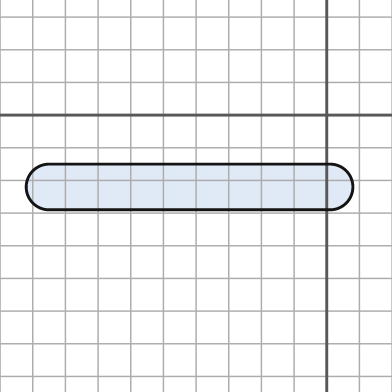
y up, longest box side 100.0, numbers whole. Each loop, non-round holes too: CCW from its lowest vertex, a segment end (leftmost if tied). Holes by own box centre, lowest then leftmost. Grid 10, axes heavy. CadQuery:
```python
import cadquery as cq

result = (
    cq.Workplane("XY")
    .moveTo(-85.0, -29.0)
    .lineTo(1.0, -29.0)
    .threePointArc((8.0, -22.0), (1.0, -15.0))
    .lineTo(-85.0, -15.0)
    .threePointArc((-92.0, -22.0), (-85.0, -29.0))
    .close()
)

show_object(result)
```